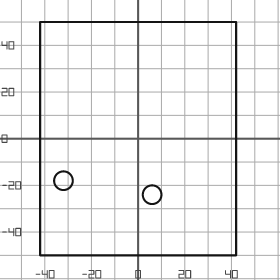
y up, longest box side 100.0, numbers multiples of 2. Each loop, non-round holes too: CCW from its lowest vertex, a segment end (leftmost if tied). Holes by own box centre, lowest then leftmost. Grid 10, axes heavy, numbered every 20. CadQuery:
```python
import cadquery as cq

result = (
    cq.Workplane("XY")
    .moveTo(-42.0, -50.0)
    .lineTo(42.0, -50.0)
    .lineTo(42.0, 50.0)
    .lineTo(-42.0, 50.0)
    .close()
    .moveTo(6.0, -24.0)
    .circle(4.0)
    .moveTo(-32.0, -18.0)
    .circle(4.0)
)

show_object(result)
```